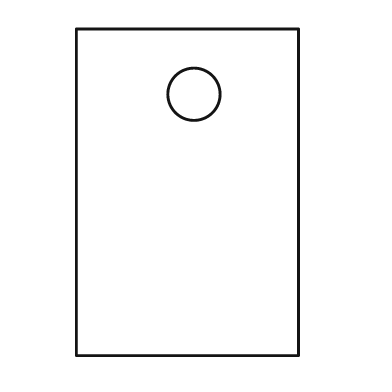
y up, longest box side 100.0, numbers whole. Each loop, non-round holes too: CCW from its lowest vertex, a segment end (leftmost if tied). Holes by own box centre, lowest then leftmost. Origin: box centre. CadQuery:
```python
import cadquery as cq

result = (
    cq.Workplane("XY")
    .moveTo(-34.0, -50.0)
    .lineTo(34.0, -50.0)
    .lineTo(34.0, 50.0)
    .lineTo(-34.0, 50.0)
    .close()
    .moveTo(2.0, 30.0)
    .circle(8.0)
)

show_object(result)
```